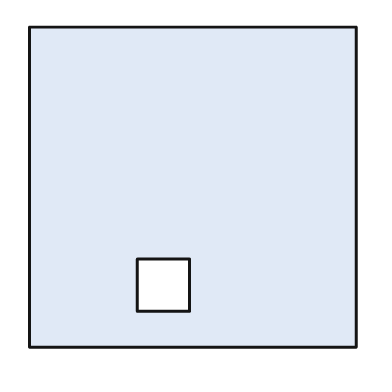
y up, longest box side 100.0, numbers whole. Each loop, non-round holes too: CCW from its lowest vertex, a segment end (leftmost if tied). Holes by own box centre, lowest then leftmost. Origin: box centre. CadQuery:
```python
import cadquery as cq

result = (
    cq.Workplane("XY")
    .moveTo(-50.0, -49.0)
    .lineTo(50.0, -49.0)
    .lineTo(50.0, 49.0)
    .lineTo(-50.0, 49.0)
    .close()
    .moveTo(-17.0, -38.0)
    .lineTo(-1.0, -38.0)
    .lineTo(-1.0, -22.0)
    .lineTo(-17.0, -22.0)
    .close()
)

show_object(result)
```